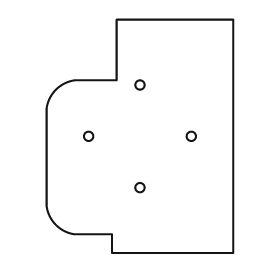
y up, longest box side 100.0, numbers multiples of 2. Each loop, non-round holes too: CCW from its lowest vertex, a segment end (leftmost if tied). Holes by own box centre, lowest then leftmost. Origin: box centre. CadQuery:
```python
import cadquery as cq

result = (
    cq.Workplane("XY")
    .moveTo(-12.0, -50.0)
    .lineTo(40.0, -50.0)
    .lineTo(40.0, 50.0)
    .lineTo(-10.0, 50.0)
    .lineTo(-10.0, 24.0)
    .lineTo(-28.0, 24.0)
    .threePointArc((-36.0, 20.0), (-40.0, 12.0))
    .lineTo(-40.0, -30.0)
    .threePointArc((-36.0, -38.0), (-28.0, -42.0))
    .lineTo(-12.0, -42.0)
    .close()
    .moveTo(0.0, -22.0)
    .circle(2.0)
    .moveTo(-22.0, 0.0)
    .circle(2.0)
    .moveTo(22.0, 0.0)
    .circle(2.0)
    .moveTo(0.0, 22.0)
    .circle(2.0)
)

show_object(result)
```